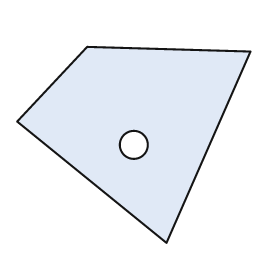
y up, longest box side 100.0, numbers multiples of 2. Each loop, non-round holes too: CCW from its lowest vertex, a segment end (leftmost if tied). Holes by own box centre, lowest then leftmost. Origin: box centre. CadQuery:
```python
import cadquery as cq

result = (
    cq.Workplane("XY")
    .moveTo(14.0, -42.0)
    .lineTo(50.0, 40.0)
    .lineTo(-20.0, 42.0)
    .lineTo(-50.0, 10.0)
    .close()
    .moveTo(0.0, 0.0)
    .circle(6.0)
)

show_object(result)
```